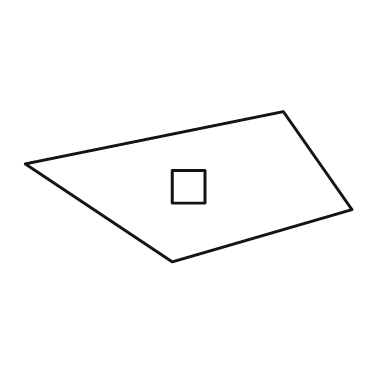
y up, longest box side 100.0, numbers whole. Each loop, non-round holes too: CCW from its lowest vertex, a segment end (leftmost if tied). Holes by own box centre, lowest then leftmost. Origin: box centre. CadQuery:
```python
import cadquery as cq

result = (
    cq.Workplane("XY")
    .moveTo(-5.0, -23.0)
    .lineTo(50.0, -7.0)
    .lineTo(29.0, 23.0)
    .lineTo(-50.0, 7.0)
    .close()
    .moveTo(-5.0, -5.0)
    .lineTo(5.0, -5.0)
    .lineTo(5.0, 5.0)
    .lineTo(-5.0, 5.0)
    .close()
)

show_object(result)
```